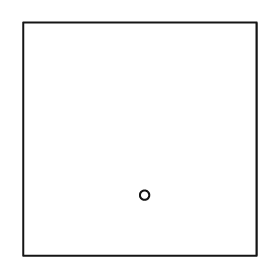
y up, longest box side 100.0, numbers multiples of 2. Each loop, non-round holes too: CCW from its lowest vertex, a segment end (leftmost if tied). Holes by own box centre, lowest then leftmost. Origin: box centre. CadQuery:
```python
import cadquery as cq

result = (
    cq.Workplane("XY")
    .moveTo(-50.0, -50.0)
    .lineTo(50.0, -50.0)
    .lineTo(50.0, 50.0)
    .lineTo(-50.0, 50.0)
    .close()
    .moveTo(2.0, -24.0)
    .circle(2.0)
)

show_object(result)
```